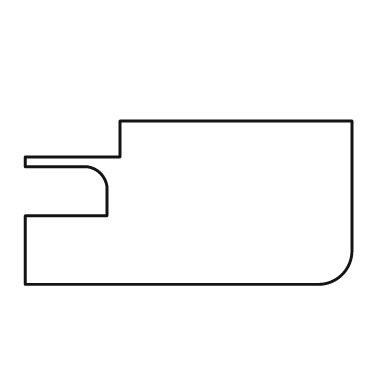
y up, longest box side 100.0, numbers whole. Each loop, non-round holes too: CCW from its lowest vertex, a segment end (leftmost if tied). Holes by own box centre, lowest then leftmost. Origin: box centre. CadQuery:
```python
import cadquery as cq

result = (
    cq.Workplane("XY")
    .moveTo(-50.0, -25.0)
    .lineTo(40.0, -25.0)
    .threePointArc((47.0, -22.0), (50.0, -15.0))
    .lineTo(50.0, 25.0)
    .lineTo(-21.0, 25.0)
    .lineTo(-21.0, 14.0)
    .lineTo(-50.0, 14.0)
    .lineTo(-50.0, 11.0)
    .lineTo(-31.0, 11.0)
    .threePointArc((-27.0, 9.0), (-25.0, 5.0))
    .lineTo(-25.0, -4.0)
    .lineTo(-50.0, -4.0)
    .close()
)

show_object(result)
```